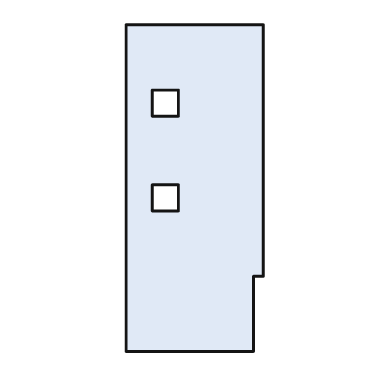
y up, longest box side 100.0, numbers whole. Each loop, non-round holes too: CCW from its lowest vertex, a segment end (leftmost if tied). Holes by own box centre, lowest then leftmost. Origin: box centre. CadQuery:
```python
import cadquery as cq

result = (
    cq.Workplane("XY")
    .moveTo(-21.0, -50.0)
    .lineTo(18.0, -50.0)
    .lineTo(18.0, -27.0)
    .lineTo(21.0, -27.0)
    .lineTo(21.0, 50.0)
    .lineTo(-21.0, 50.0)
    .close()
    .moveTo(-13.0, -7.0)
    .lineTo(-5.0, -7.0)
    .lineTo(-5.0, 1.0)
    .lineTo(-13.0, 1.0)
    .close()
    .moveTo(-13.0, 22.0)
    .lineTo(-5.0, 22.0)
    .lineTo(-5.0, 30.0)
    .lineTo(-13.0, 30.0)
    .close()
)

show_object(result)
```